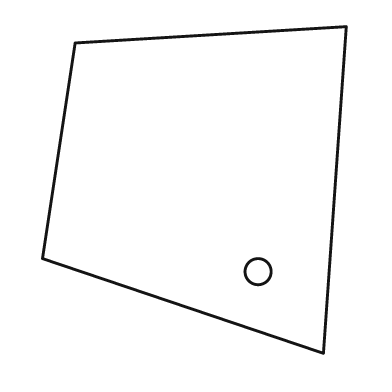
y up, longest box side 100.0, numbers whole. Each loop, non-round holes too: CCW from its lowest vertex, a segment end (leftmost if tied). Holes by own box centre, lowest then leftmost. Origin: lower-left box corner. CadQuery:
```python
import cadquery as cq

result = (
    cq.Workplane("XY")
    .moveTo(86.0, 0.0)
    .lineTo(93.0, 100.0)
    .lineTo(10.0, 95.0)
    .lineTo(0.0, 29.0)
    .close()
    .moveTo(66.0, 25.0)
    .circle(4.0)
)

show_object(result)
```